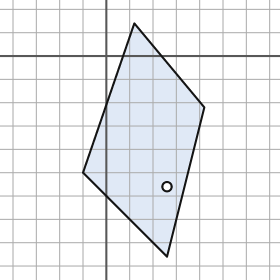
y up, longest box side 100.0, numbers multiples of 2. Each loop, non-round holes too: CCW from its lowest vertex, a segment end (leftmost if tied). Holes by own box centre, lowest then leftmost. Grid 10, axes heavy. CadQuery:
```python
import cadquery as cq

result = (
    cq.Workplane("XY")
    .moveTo(26.0, -86.0)
    .lineTo(42.0, -22.0)
    .lineTo(12.0, 14.0)
    .lineTo(-10.0, -50.0)
    .close()
    .moveTo(26.0, -56.0)
    .circle(2.0)
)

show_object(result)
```